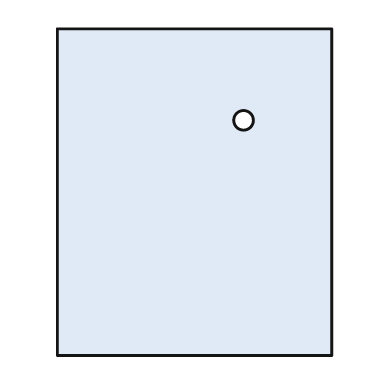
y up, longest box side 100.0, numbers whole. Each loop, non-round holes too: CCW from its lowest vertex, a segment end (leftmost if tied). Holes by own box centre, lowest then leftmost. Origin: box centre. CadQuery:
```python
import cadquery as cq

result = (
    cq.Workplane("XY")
    .moveTo(-42.0, -50.0)
    .lineTo(42.0, -50.0)
    .lineTo(42.0, 50.0)
    .lineTo(-42.0, 50.0)
    .close()
    .moveTo(15.0, 22.0)
    .circle(3.0)
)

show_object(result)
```